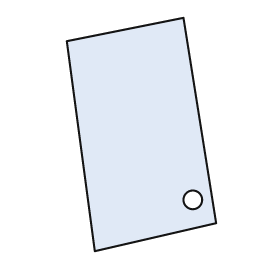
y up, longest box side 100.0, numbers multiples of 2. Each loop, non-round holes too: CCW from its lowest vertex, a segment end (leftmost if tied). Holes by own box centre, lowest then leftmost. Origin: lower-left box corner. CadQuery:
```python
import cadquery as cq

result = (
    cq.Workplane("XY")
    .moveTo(12.0, 0.0)
    .lineTo(64.0, 12.0)
    .lineTo(50.0, 100.0)
    .lineTo(0.0, 90.0)
    .close()
    .moveTo(54.0, 22.0)
    .circle(4.0)
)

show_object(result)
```